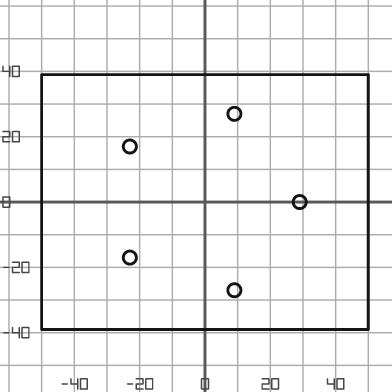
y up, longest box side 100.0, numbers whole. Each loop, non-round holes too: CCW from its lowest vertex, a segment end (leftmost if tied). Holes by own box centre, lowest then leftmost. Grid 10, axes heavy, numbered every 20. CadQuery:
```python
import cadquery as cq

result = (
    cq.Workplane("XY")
    .moveTo(-50.0, -39.0)
    .lineTo(50.0, -39.0)
    .lineTo(50.0, 39.0)
    .lineTo(-50.0, 39.0)
    .close()
    .moveTo(9.0, -27.0)
    .circle(2.0)
    .moveTo(-23.0, -17.0)
    .circle(2.0)
    .moveTo(29.0, 0.0)
    .circle(2.0)
    .moveTo(-23.0, 17.0)
    .circle(2.0)
    .moveTo(9.0, 27.0)
    .circle(2.0)
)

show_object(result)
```